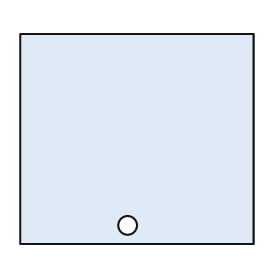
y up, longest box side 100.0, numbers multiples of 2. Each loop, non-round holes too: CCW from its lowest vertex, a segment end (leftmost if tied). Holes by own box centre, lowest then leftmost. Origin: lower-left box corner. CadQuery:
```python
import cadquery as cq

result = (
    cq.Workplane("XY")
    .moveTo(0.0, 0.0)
    .lineTo(100.0, 0.0)
    .lineTo(100.0, 90.0)
    .lineTo(0.0, 90.0)
    .close()
    .moveTo(46.0, 8.0)
    .circle(4.0)
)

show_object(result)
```